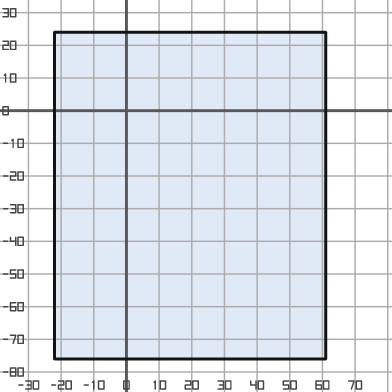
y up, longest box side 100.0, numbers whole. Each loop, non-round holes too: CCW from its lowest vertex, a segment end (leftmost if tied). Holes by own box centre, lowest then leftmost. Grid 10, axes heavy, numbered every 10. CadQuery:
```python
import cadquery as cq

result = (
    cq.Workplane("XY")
    .moveTo(-22.0, -76.0)
    .lineTo(61.0, -76.0)
    .lineTo(61.0, 24.0)
    .lineTo(-22.0, 24.0)
    .close()
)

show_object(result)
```